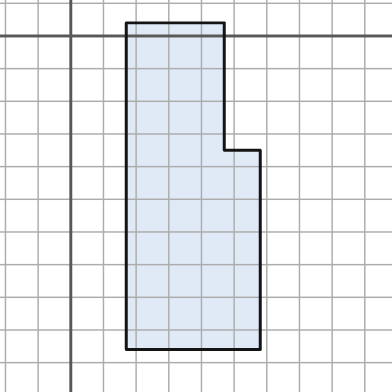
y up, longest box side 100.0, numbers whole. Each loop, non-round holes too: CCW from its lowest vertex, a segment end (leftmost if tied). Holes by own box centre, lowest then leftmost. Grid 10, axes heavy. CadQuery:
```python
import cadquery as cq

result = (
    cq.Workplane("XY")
    .moveTo(17.0, -96.0)
    .lineTo(58.0, -96.0)
    .lineTo(58.0, -35.0)
    .lineTo(47.0, -35.0)
    .lineTo(47.0, 4.0)
    .lineTo(17.0, 4.0)
    .close()
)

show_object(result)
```